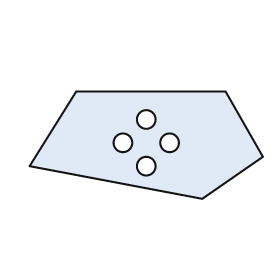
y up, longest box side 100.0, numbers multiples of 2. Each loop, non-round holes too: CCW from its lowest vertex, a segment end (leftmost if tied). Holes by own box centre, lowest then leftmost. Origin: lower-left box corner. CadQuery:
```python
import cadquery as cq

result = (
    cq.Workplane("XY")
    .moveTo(74.0, 0.0)
    .lineTo(100.0, 18.0)
    .lineTo(84.0, 46.0)
    .lineTo(20.0, 46.0)
    .lineTo(0.0, 14.0)
    .close()
    .moveTo(50.0, 14.0)
    .circle(4.0)
    .moveTo(40.0, 24.0)
    .circle(4.0)
    .moveTo(60.0, 24.0)
    .circle(4.0)
    .moveTo(50.0, 34.0)
    .circle(4.0)
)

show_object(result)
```